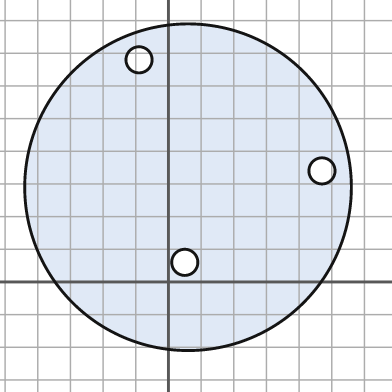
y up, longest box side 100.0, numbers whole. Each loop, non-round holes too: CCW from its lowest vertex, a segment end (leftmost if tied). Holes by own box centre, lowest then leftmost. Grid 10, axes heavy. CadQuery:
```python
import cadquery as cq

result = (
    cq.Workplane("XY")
    .moveTo(6.0, 29.0)
    .circle(50.0)
    .moveTo(5.0, 6.0)
    .circle(4.0)
    .moveTo(47.0, 34.0)
    .circle(4.0)
    .moveTo(-9.0, 68.0)
    .circle(4.0)
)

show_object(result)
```